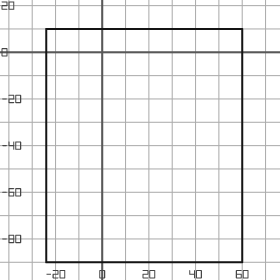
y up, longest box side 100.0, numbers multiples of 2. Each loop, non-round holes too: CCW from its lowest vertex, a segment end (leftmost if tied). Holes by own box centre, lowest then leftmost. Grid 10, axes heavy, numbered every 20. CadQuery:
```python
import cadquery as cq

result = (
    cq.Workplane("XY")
    .moveTo(-24.0, -90.0)
    .lineTo(60.0, -90.0)
    .lineTo(60.0, 10.0)
    .lineTo(-24.0, 10.0)
    .close()
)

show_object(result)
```